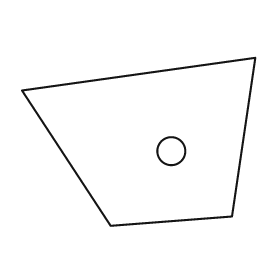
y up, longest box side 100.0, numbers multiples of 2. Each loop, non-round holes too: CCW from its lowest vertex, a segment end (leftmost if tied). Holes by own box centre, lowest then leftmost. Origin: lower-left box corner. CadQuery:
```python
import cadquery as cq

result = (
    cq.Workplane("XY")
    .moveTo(38.0, 0.0)
    .lineTo(90.0, 4.0)
    .lineTo(100.0, 72.0)
    .lineTo(0.0, 58.0)
    .close()
    .moveTo(64.0, 32.0)
    .circle(6.0)
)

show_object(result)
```